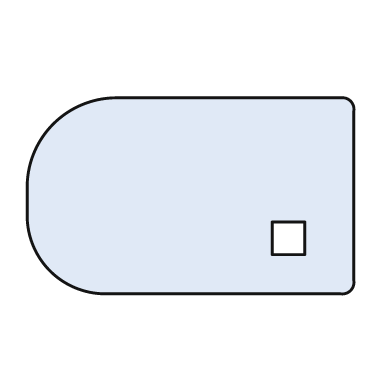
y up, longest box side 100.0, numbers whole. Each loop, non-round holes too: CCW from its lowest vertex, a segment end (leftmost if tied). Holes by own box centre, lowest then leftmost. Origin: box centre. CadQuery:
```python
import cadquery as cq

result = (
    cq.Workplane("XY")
    .moveTo(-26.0, -30.0)
    .lineTo(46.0, -30.0)
    .threePointArc((49.0, -29.0), (50.0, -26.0))
    .lineTo(50.0, 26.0)
    .threePointArc((49.0, 29.0), (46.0, 30.0))
    .lineTo(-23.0, 30.0)
    .threePointArc((-42.0, 22.0), (-50.0, 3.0))
    .lineTo(-50.0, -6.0)
    .threePointArc((-43.0, -23.0), (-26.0, -30.0))
    .close()
    .moveTo(25.0, -18.0)
    .lineTo(35.0, -18.0)
    .lineTo(35.0, -8.0)
    .lineTo(25.0, -8.0)
    .close()
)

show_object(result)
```